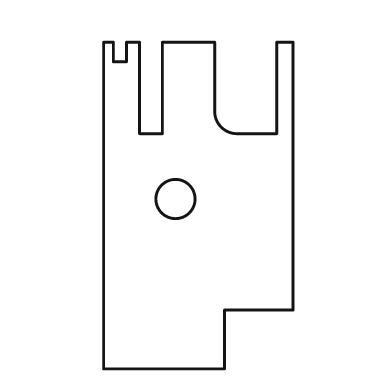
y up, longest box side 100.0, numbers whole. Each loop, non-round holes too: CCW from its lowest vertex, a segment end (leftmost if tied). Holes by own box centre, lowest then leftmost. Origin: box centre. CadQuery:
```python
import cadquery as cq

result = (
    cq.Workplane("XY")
    .moveTo(-29.0, -50.0)
    .lineTo(8.0, -50.0)
    .lineTo(8.0, -32.0)
    .lineTo(29.0, -32.0)
    .lineTo(29.0, 50.0)
    .lineTo(24.0, 50.0)
    .lineTo(24.0, 22.0)
    .lineTo(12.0, 22.0)
    .threePointArc((7.0, 24.0), (5.0, 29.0))
    .lineTo(5.0, 50.0)
    .lineTo(-11.0, 50.0)
    .lineTo(-11.0, 22.0)
    .lineTo(-18.0, 22.0)
    .lineTo(-18.0, 50.0)
    .lineTo(-22.0, 50.0)
    .lineTo(-22.0, 44.0)
    .lineTo(-26.0, 44.0)
    .lineTo(-26.0, 50.0)
    .lineTo(-29.0, 50.0)
    .close()
    .moveTo(-7.0, 2.0)
    .circle(6.0)
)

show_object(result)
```